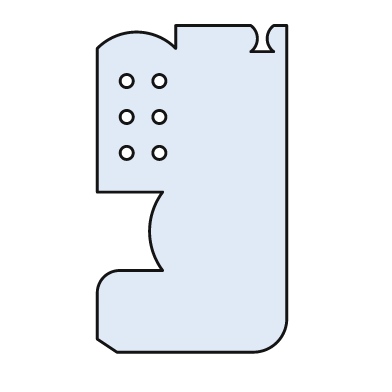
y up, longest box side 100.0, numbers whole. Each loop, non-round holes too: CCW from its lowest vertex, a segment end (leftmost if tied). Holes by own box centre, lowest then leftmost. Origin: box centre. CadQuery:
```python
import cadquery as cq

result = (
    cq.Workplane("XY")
    .moveTo(-23.0, -50.0)
    .lineTo(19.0, -50.0)
    .threePointArc((26.0, -47.0), (29.0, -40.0))
    .lineTo(29.0, 50.0)
    .lineTo(25.0, 50.0)
    .threePointArc((23.0, 46.0), (25.0, 42.0))
    .lineTo(18.0, 42.0)
    .threePointArc((20.0, 46.0), (18.0, 50.0))
    .lineTo(-5.0, 50.0)
    .lineTo(-5.0, 43.0)
    .threePointArc((-17.0, 48.0), (-29.0, 43.0))
    .lineTo(-29.0, -1.0)
    .lineTo(-9.0, -1.0)
    .threePointArc((-13.0, -13.0), (-9.0, -25.0))
    .lineTo(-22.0, -25.0)
    .threePointArc((-27.0, -27.0), (-29.0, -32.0))
    .lineTo(-29.0, -46.0)
    .close()
    .moveTo(-20.0, 11.0)
    .circle(2.0)
    .moveTo(-10.0, 11.0)
    .circle(2.0)
    .moveTo(-20.0, 22.0)
    .circle(2.0)
    .moveTo(-10.0, 22.0)
    .circle(2.0)
    .moveTo(-20.0, 33.0)
    .circle(2.0)
    .moveTo(-10.0, 33.0)
    .circle(2.0)
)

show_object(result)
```